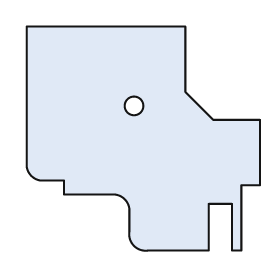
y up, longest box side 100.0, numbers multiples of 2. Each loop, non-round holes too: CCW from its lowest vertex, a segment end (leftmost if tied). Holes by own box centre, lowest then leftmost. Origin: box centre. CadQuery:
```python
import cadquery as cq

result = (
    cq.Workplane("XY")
    .moveTo(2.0, -48.0)
    .lineTo(28.0, -48.0)
    .lineTo(28.0, -28.0)
    .lineTo(38.0, -28.0)
    .lineTo(38.0, -48.0)
    .lineTo(42.0, -48.0)
    .lineTo(42.0, -20.0)
    .lineTo(50.0, -20.0)
    .lineTo(50.0, 8.0)
    .lineTo(30.0, 8.0)
    .lineTo(18.0, 20.0)
    .lineTo(18.0, 48.0)
    .lineTo(-50.0, 48.0)
    .lineTo(-50.0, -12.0)
    .threePointArc((-48.0, -16.0), (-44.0, -18.0))
    .lineTo(-34.0, -18.0)
    .lineTo(-34.0, -24.0)
    .lineTo(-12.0, -24.0)
    .threePointArc((-8.0, -26.0), (-6.0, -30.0))
    .lineTo(-6.0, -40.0)
    .threePointArc((-4.0, -46.0), (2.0, -48.0))
    .close()
    .moveTo(-4.0, 14.0)
    .circle(4.0)
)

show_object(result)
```